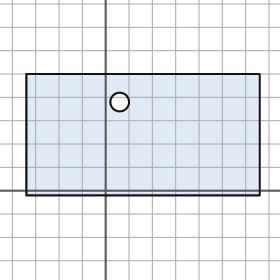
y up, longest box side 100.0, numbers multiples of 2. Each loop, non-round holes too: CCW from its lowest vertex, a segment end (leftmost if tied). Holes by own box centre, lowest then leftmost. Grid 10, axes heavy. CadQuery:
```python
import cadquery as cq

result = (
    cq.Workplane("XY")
    .moveTo(-34.0, -2.0)
    .lineTo(66.0, -2.0)
    .lineTo(66.0, 50.0)
    .lineTo(-34.0, 50.0)
    .close()
    .moveTo(6.0, 38.0)
    .circle(4.0)
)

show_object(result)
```